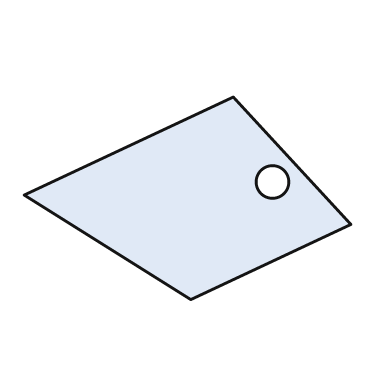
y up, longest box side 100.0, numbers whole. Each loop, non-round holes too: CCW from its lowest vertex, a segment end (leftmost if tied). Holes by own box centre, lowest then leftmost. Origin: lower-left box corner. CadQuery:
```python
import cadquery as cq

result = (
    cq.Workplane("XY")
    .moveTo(51.0, 0.0)
    .lineTo(100.0, 23.0)
    .lineTo(64.0, 62.0)
    .lineTo(0.0, 32.0)
    .close()
    .moveTo(76.0, 36.0)
    .circle(5.0)
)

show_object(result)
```